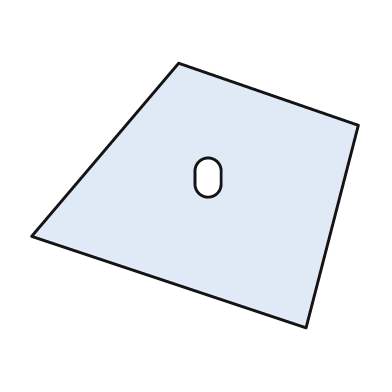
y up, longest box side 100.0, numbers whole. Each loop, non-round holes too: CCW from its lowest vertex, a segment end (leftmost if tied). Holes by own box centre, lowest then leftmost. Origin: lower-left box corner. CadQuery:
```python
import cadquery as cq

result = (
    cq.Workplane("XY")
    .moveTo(84.0, 0.0)
    .lineTo(100.0, 62.0)
    .lineTo(45.0, 81.0)
    .lineTo(0.0, 28.0)
    .close()
    .moveTo(50.0, 44.0)
    .threePointArc((54.0, 40.0), (58.0, 44.0))
    .lineTo(58.0, 48.0)
    .threePointArc((54.0, 52.0), (50.0, 48.0))
    .close()
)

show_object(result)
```